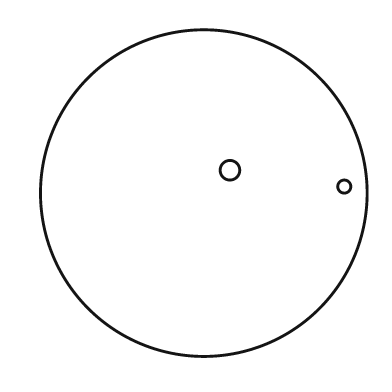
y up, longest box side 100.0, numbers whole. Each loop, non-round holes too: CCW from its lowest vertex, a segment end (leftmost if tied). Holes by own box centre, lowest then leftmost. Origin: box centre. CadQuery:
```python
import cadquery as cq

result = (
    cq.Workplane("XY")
    .moveTo(0.0, 0.0)
    .circle(50.0)
    .moveTo(43.0, 2.0)
    .circle(2.0)
    .moveTo(8.0, 7.0)
    .circle(3.0)
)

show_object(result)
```